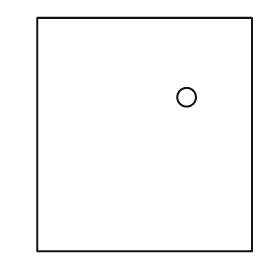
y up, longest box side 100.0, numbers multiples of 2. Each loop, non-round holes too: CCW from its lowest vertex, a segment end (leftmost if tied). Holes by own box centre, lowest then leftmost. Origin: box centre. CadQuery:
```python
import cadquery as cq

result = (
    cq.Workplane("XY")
    .moveTo(-46.0, -50.0)
    .lineTo(46.0, -50.0)
    .lineTo(46.0, 50.0)
    .lineTo(-46.0, 50.0)
    .close()
    .moveTo(18.0, 16.0)
    .circle(4.0)
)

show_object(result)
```